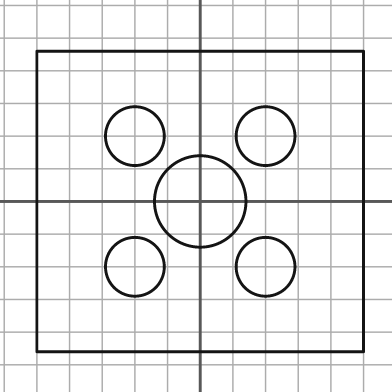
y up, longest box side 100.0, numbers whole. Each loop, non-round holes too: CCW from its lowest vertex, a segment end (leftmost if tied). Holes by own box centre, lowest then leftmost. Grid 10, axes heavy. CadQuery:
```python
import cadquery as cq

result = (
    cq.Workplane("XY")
    .moveTo(-50.0, -46.0)
    .lineTo(50.0, -46.0)
    .lineTo(50.0, 46.0)
    .lineTo(-50.0, 46.0)
    .close()
    .moveTo(-20.0, -20.0)
    .circle(9.0)
    .moveTo(20.0, -20.0)
    .circle(9.0)
    .moveTo(0.0, 0.0)
    .circle(14.0)
    .moveTo(-20.0, 20.0)
    .circle(9.0)
    .moveTo(20.0, 20.0)
    .circle(9.0)
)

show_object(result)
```